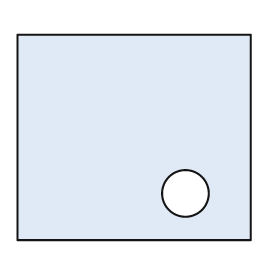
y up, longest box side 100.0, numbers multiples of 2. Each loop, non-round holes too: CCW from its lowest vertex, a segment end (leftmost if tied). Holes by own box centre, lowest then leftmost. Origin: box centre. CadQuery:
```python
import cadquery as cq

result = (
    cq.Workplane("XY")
    .moveTo(-50.0, -44.0)
    .lineTo(50.0, -44.0)
    .lineTo(50.0, 44.0)
    .lineTo(-50.0, 44.0)
    .close()
    .moveTo(22.0, -24.0)
    .circle(10.0)
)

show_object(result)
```